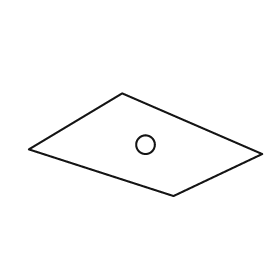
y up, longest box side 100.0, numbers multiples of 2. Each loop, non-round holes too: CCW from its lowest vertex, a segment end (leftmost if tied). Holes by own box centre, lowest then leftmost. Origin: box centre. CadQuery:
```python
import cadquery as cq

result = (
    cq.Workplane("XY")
    .moveTo(12.0, -22.0)
    .lineTo(50.0, -4.0)
    .lineTo(-10.0, 22.0)
    .lineTo(-50.0, -2.0)
    .close()
    .moveTo(0.0, 0.0)
    .circle(4.0)
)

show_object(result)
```